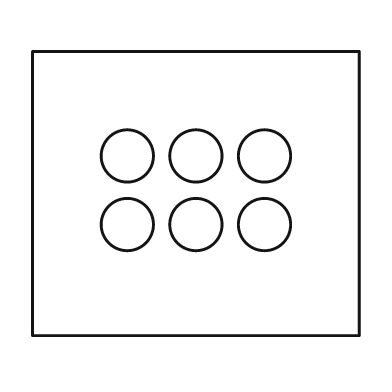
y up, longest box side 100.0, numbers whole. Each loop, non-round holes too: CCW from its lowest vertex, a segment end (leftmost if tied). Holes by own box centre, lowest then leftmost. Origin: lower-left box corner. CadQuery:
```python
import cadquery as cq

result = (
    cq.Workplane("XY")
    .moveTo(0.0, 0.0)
    .lineTo(100.0, 0.0)
    .lineTo(100.0, 87.0)
    .lineTo(0.0, 87.0)
    .close()
    .moveTo(29.0, 34.0)
    .circle(8.0)
    .moveTo(50.0, 34.0)
    .circle(8.0)
    .moveTo(71.0, 34.0)
    .circle(8.0)
    .moveTo(29.0, 55.0)
    .circle(8.0)
    .moveTo(50.0, 55.0)
    .circle(8.0)
    .moveTo(71.0, 55.0)
    .circle(8.0)
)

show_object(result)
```